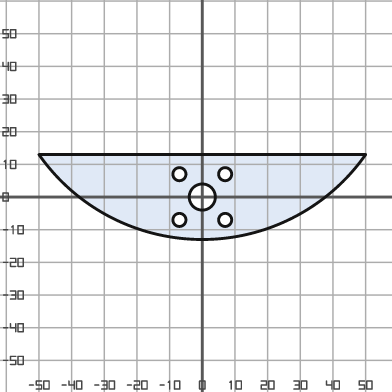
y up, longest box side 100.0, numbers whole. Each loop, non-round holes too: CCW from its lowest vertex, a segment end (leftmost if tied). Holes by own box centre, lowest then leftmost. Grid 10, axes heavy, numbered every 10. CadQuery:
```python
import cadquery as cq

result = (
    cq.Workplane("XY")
    .moveTo(-50.0, 13.0)
    .threePointArc((0.0, -13.0), (50.0, 13.0))
    .close()
    .moveTo(-7.0, -7.0)
    .circle(2.0)
    .moveTo(7.0, -7.0)
    .circle(2.0)
    .moveTo(0.0, 0.0)
    .circle(4.0)
    .moveTo(-7.0, 7.0)
    .circle(2.0)
    .moveTo(7.0, 7.0)
    .circle(2.0)
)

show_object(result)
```